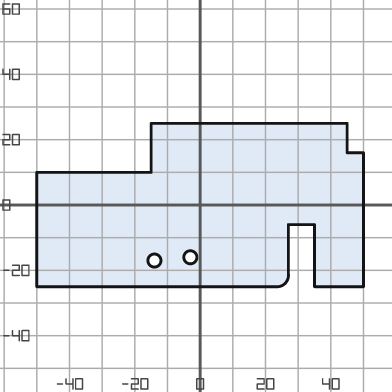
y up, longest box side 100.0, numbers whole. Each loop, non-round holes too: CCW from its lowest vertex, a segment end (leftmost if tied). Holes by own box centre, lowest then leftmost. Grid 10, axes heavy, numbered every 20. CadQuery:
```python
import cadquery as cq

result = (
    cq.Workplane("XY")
    .moveTo(-50.0, -25.0)
    .lineTo(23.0, -25.0)
    .threePointArc((26.0, -24.0), (27.0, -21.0))
    .lineTo(27.0, -6.0)
    .lineTo(35.0, -6.0)
    .lineTo(35.0, -25.0)
    .lineTo(50.0, -25.0)
    .lineTo(50.0, 16.0)
    .lineTo(45.0, 16.0)
    .lineTo(45.0, 25.0)
    .lineTo(-15.0, 25.0)
    .lineTo(-15.0, 10.0)
    .lineTo(-50.0, 10.0)
    .close()
    .moveTo(-14.0, -17.0)
    .circle(2.0)
    .moveTo(-3.0, -16.0)
    .circle(2.0)
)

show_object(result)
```